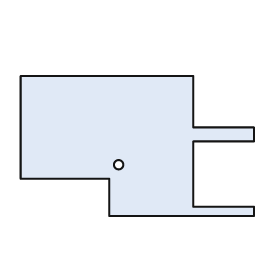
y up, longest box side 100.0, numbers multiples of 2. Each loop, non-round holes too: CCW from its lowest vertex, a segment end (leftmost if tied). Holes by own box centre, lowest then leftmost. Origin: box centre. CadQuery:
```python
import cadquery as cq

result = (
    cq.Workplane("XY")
    .moveTo(-12.0, -30.0)
    .lineTo(50.0, -30.0)
    .lineTo(50.0, -26.0)
    .lineTo(24.0, -26.0)
    .lineTo(24.0, 2.0)
    .lineTo(50.0, 2.0)
    .lineTo(50.0, 8.0)
    .lineTo(24.0, 8.0)
    .lineTo(24.0, 30.0)
    .lineTo(-50.0, 30.0)
    .lineTo(-50.0, -14.0)
    .lineTo(-12.0, -14.0)
    .close()
    .moveTo(-8.0, -8.0)
    .circle(2.0)
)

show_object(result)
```